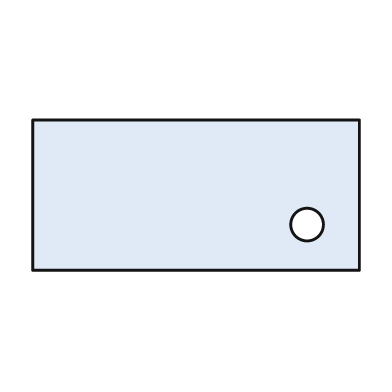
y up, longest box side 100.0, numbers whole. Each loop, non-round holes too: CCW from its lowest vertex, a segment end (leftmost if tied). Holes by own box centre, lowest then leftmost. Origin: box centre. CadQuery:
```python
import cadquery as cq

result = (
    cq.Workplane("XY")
    .moveTo(-50.0, -23.0)
    .lineTo(50.0, -23.0)
    .lineTo(50.0, 23.0)
    .lineTo(-50.0, 23.0)
    .close()
    .moveTo(34.0, -9.0)
    .circle(5.0)
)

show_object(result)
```